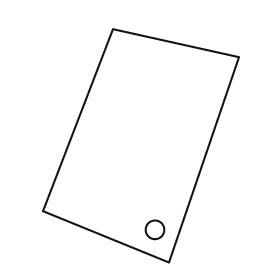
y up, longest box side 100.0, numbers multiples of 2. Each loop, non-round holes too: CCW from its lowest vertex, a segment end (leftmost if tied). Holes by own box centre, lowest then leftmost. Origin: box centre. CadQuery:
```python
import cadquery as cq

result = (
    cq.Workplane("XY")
    .moveTo(12.0, -50.0)
    .lineTo(42.0, 38.0)
    .lineTo(-12.0, 50.0)
    .lineTo(-42.0, -28.0)
    .close()
    .moveTo(6.0, -36.0)
    .circle(4.0)
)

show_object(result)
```